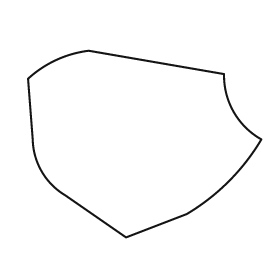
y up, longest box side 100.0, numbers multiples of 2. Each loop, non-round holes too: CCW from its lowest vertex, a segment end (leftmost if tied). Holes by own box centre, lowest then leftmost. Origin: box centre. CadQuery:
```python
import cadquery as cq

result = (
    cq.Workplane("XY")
    .moveTo(-8.0, -40.0)
    .lineTo(18.0, -30.0)
    .threePointArc((36.0, -16.0), (50.0, 2.0))
    .threePointArc((38.0, 14.0), (34.0, 30.0))
    .lineTo(-24.0, 40.0)
    .threePointArc((-38.0, 36.0), (-50.0, 28.0))
    .lineTo(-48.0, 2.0)
    .threePointArc((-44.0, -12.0), (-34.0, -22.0))
    .close()
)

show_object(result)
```